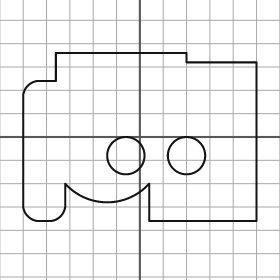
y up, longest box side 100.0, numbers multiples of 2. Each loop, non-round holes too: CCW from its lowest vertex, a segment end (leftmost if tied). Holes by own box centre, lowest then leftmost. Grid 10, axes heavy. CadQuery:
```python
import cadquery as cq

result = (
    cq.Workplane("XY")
    .moveTo(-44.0, -36.0)
    .lineTo(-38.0, -36.0)
    .threePointArc((-34.0, -34.0), (-32.0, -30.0))
    .lineTo(-32.0, -20.0)
    .threePointArc((-14.0, -28.0), (4.0, -20.0))
    .lineTo(4.0, -36.0)
    .lineTo(50.0, -36.0)
    .lineTo(50.0, 32.0)
    .lineTo(20.0, 32.0)
    .lineTo(20.0, 36.0)
    .lineTo(-36.0, 36.0)
    .lineTo(-36.0, 24.0)
    .lineTo(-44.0, 24.0)
    .threePointArc((-48.0, 22.0), (-50.0, 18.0))
    .lineTo(-50.0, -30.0)
    .threePointArc((-48.0, -34.0), (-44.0, -36.0))
    .close()
    .moveTo(-6.0, -8.0)
    .circle(8.0)
    .moveTo(20.0, -8.0)
    .circle(8.0)
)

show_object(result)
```